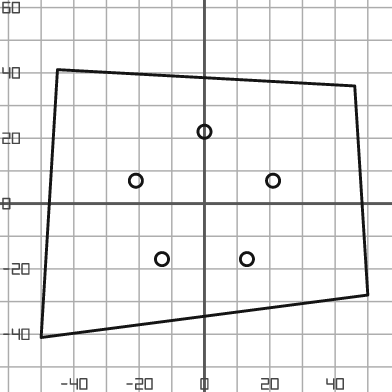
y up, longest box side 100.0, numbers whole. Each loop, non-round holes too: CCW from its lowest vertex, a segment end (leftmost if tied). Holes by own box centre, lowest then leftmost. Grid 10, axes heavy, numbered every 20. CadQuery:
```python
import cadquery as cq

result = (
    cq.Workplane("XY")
    .moveTo(-50.0, -41.0)
    .lineTo(50.0, -28.0)
    .lineTo(46.0, 36.0)
    .lineTo(-45.0, 41.0)
    .close()
    .moveTo(-13.0, -17.0)
    .circle(2.0)
    .moveTo(13.0, -17.0)
    .circle(2.0)
    .moveTo(-21.0, 7.0)
    .circle(2.0)
    .moveTo(21.0, 7.0)
    .circle(2.0)
    .moveTo(0.0, 22.0)
    .circle(2.0)
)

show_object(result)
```